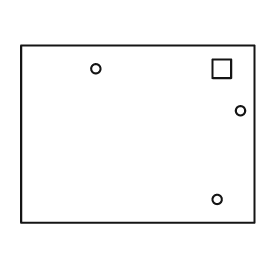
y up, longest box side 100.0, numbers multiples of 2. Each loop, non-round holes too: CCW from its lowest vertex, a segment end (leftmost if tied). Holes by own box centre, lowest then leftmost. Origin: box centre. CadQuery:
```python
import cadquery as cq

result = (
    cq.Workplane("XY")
    .moveTo(-50.0, -38.0)
    .lineTo(50.0, -38.0)
    .lineTo(50.0, 38.0)
    .lineTo(-50.0, 38.0)
    .close()
    .moveTo(34.0, -28.0)
    .circle(2.0)
    .moveTo(44.0, 10.0)
    .circle(2.0)
    .moveTo(-18.0, 28.0)
    .circle(2.0)
    .moveTo(32.0, 24.0)
    .lineTo(40.0, 24.0)
    .lineTo(40.0, 32.0)
    .lineTo(32.0, 32.0)
    .close()
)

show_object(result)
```